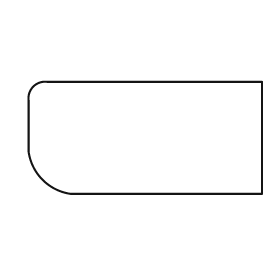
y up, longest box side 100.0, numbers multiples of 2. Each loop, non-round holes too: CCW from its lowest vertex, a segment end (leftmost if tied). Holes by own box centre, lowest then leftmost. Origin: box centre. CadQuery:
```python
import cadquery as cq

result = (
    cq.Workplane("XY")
    .moveTo(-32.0, -24.0)
    .lineTo(50.0, -24.0)
    .lineTo(50.0, 24.0)
    .lineTo(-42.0, 24.0)
    .threePointArc((-48.0, 22.0), (-50.0, 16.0))
    .lineTo(-50.0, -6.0)
    .threePointArc((-44.0, -18.0), (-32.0, -24.0))
    .close()
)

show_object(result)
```